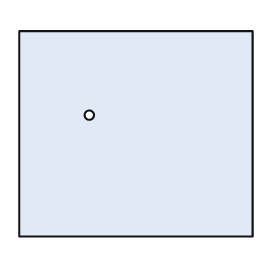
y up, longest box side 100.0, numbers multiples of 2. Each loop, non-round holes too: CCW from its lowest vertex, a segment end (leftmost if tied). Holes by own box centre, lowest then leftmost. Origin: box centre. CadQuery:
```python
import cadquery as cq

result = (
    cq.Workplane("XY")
    .moveTo(-50.0, -44.0)
    .lineTo(50.0, -44.0)
    .lineTo(50.0, 44.0)
    .lineTo(-50.0, 44.0)
    .close()
    .moveTo(-20.0, 8.0)
    .circle(2.0)
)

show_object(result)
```